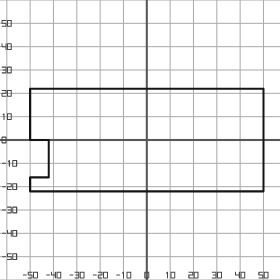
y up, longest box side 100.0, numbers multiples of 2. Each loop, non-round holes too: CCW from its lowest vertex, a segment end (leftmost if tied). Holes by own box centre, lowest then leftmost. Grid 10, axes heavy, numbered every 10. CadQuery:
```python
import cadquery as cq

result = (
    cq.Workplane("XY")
    .moveTo(-50.0, -22.0)
    .lineTo(50.0, -22.0)
    .lineTo(50.0, 22.0)
    .lineTo(-50.0, 22.0)
    .lineTo(-50.0, 0.0)
    .lineTo(-42.0, 0.0)
    .lineTo(-42.0, -16.0)
    .lineTo(-50.0, -16.0)
    .close()
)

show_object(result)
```